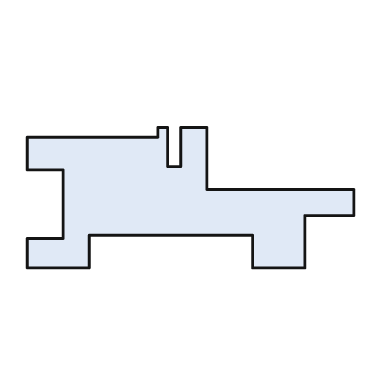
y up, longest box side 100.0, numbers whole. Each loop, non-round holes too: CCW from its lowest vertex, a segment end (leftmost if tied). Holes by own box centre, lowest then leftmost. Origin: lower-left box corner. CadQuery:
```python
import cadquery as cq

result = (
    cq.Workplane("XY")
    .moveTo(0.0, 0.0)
    .lineTo(19.0, 0.0)
    .lineTo(19.0, 10.0)
    .lineTo(69.0, 10.0)
    .lineTo(69.0, 0.0)
    .lineTo(85.0, 0.0)
    .lineTo(85.0, 16.0)
    .lineTo(100.0, 16.0)
    .lineTo(100.0, 24.0)
    .lineTo(55.0, 24.0)
    .lineTo(55.0, 43.0)
    .lineTo(47.0, 43.0)
    .lineTo(47.0, 31.0)
    .lineTo(43.0, 31.0)
    .lineTo(43.0, 43.0)
    .lineTo(40.0, 43.0)
    .lineTo(40.0, 40.0)
    .lineTo(0.0, 40.0)
    .lineTo(0.0, 30.0)
    .lineTo(11.0, 30.0)
    .lineTo(11.0, 9.0)
    .lineTo(0.0, 9.0)
    .close()
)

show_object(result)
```